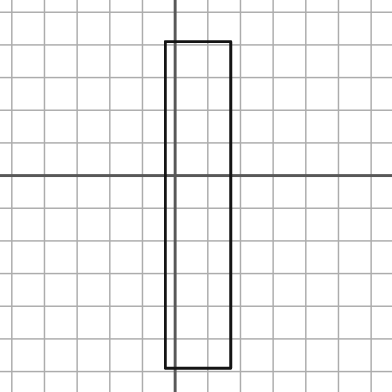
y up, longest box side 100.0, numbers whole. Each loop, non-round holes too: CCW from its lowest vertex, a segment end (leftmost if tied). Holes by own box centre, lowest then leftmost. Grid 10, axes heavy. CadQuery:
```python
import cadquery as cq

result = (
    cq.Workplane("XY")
    .moveTo(-3.0, -59.0)
    .lineTo(17.0, -59.0)
    .lineTo(17.0, 41.0)
    .lineTo(-3.0, 41.0)
    .close()
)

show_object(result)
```